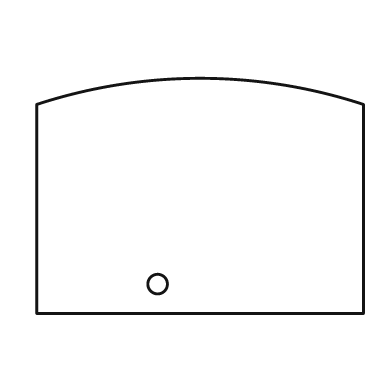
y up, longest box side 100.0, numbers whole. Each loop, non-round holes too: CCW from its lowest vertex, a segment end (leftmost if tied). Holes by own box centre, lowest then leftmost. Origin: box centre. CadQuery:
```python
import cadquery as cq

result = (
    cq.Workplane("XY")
    .moveTo(-50.0, -36.0)
    .lineTo(50.0, -36.0)
    .lineTo(50.0, 28.0)
    .threePointArc((0.0, 36.0), (-50.0, 28.0))
    .close()
    .moveTo(-13.0, -27.0)
    .circle(3.0)
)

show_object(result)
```